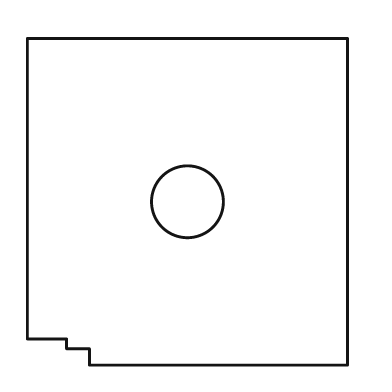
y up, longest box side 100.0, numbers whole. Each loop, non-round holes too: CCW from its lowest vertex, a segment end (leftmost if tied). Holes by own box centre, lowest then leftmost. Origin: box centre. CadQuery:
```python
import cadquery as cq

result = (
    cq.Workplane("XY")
    .moveTo(-30.0, -50.0)
    .lineTo(49.0, -50.0)
    .lineTo(49.0, 50.0)
    .lineTo(-49.0, 50.0)
    .lineTo(-49.0, -42.0)
    .lineTo(-37.0, -42.0)
    .lineTo(-37.0, -45.0)
    .lineTo(-30.0, -45.0)
    .close()
    .moveTo(0.0, 0.0)
    .circle(11.0)
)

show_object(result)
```